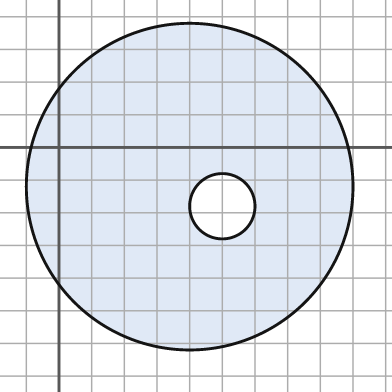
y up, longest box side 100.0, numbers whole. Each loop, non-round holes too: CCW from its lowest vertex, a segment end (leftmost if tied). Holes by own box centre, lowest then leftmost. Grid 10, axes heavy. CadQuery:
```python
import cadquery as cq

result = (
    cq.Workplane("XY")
    .moveTo(40.0, -12.0)
    .circle(50.0)
    .moveTo(50.0, -18.0)
    .circle(10.0)
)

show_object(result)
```